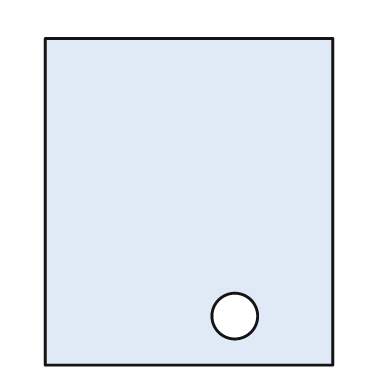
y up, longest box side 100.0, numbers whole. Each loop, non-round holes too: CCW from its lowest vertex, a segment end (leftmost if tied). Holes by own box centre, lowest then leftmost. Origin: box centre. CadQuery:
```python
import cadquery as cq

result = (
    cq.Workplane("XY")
    .moveTo(-44.0, -50.0)
    .lineTo(44.0, -50.0)
    .lineTo(44.0, 50.0)
    .lineTo(-44.0, 50.0)
    .close()
    .moveTo(14.0, -35.0)
    .circle(7.0)
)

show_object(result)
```